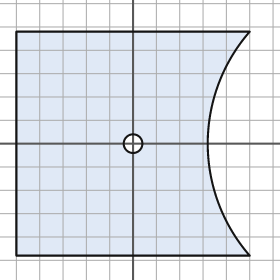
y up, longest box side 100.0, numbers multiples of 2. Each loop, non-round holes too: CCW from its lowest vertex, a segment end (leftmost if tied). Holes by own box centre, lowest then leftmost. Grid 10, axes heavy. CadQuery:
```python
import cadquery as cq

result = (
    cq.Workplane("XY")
    .moveTo(-50.0, -48.0)
    .lineTo(50.0, -48.0)
    .threePointArc((32.0, 0.0), (50.0, 48.0))
    .lineTo(-50.0, 48.0)
    .close()
    .moveTo(0.0, 0.0)
    .circle(4.0)
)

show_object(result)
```